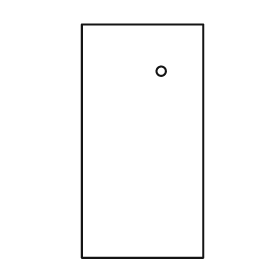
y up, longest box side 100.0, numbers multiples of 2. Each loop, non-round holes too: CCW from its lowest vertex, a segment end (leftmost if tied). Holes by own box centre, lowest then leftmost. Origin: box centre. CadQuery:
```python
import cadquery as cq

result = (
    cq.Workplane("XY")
    .moveTo(-26.0, -50.0)
    .lineTo(26.0, -50.0)
    .lineTo(26.0, 50.0)
    .lineTo(-26.0, 50.0)
    .close()
    .moveTo(8.0, 30.0)
    .circle(2.0)
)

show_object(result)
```